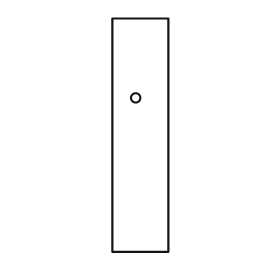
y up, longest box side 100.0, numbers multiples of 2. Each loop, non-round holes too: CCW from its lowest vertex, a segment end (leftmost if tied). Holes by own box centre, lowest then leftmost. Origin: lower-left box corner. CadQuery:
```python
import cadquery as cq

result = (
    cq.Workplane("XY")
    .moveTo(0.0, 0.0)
    .lineTo(24.0, 0.0)
    .lineTo(24.0, 100.0)
    .lineTo(0.0, 100.0)
    .close()
    .moveTo(10.0, 66.0)
    .circle(2.0)
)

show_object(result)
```